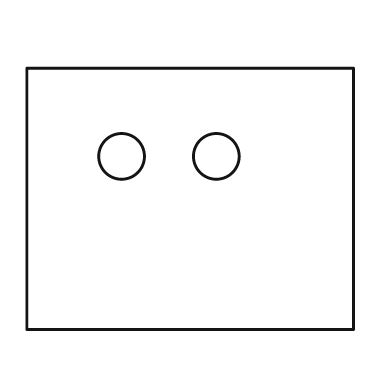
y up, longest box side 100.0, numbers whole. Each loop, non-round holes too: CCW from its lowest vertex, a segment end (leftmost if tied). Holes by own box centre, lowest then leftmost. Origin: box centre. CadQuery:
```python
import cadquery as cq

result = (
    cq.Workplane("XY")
    .moveTo(-50.0, -40.0)
    .lineTo(50.0, -40.0)
    .lineTo(50.0, 40.0)
    .lineTo(-50.0, 40.0)
    .close()
    .moveTo(-21.0, 13.0)
    .circle(7.0)
    .moveTo(8.0, 13.0)
    .circle(7.0)
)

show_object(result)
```